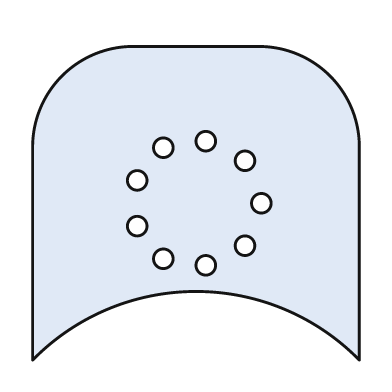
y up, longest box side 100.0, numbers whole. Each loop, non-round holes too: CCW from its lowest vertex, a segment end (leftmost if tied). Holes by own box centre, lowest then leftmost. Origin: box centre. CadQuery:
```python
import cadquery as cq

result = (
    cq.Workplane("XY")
    .moveTo(-50.0, -48.0)
    .threePointArc((0.0, -27.0), (50.0, -48.0))
    .lineTo(50.0, 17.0)
    .threePointArc((41.0, 39.0), (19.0, 48.0))
    .lineTo(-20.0, 48.0)
    .threePointArc((-41.0, 39.0), (-50.0, 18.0))
    .close()
    .moveTo(3.0, -19.0)
    .circle(3.0)
    .moveTo(-10.0, -17.0)
    .circle(3.0)
    .moveTo(15.0, -13.0)
    .circle(3.0)
    .moveTo(-18.0, -7.0)
    .circle(3.0)
    .moveTo(20.0, 0.0)
    .circle(3.0)
    .moveTo(-18.0, 7.0)
    .circle(3.0)
    .moveTo(15.0, 13.0)
    .circle(3.0)
    .moveTo(-10.0, 17.0)
    .circle(3.0)
    .moveTo(3.0, 19.0)
    .circle(3.0)
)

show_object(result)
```